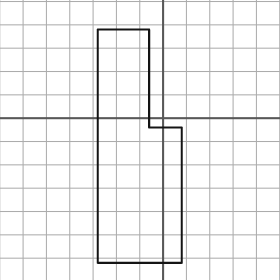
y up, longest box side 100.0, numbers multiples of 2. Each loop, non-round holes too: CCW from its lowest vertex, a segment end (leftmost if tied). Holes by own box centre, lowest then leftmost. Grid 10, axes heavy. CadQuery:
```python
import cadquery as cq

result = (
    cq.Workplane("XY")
    .moveTo(-28.0, -62.0)
    .lineTo(8.0, -62.0)
    .lineTo(8.0, -4.0)
    .lineTo(-6.0, -4.0)
    .lineTo(-6.0, 38.0)
    .lineTo(-28.0, 38.0)
    .close()
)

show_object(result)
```